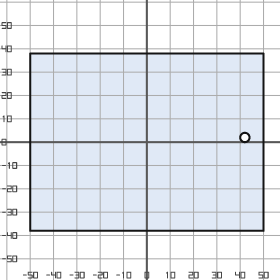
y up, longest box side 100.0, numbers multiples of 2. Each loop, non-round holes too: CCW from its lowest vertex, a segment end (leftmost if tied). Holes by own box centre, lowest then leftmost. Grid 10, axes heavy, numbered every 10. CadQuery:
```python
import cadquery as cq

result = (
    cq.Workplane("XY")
    .moveTo(-50.0, -38.0)
    .lineTo(50.0, -38.0)
    .lineTo(50.0, 38.0)
    .lineTo(-50.0, 38.0)
    .close()
    .moveTo(42.0, 2.0)
    .circle(2.0)
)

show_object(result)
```